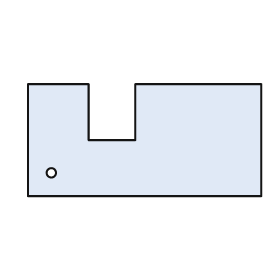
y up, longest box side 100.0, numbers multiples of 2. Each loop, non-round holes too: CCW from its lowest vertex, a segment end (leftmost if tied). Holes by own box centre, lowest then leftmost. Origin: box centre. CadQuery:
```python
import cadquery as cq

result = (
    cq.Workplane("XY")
    .moveTo(-50.0, -24.0)
    .lineTo(50.0, -24.0)
    .lineTo(50.0, 24.0)
    .lineTo(-4.0, 24.0)
    .lineTo(-4.0, 0.0)
    .lineTo(-24.0, 0.0)
    .lineTo(-24.0, 24.0)
    .lineTo(-50.0, 24.0)
    .close()
    .moveTo(-40.0, -14.0)
    .circle(2.0)
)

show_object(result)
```